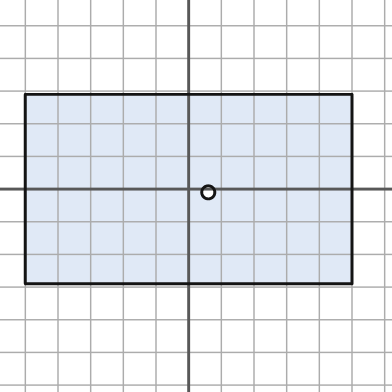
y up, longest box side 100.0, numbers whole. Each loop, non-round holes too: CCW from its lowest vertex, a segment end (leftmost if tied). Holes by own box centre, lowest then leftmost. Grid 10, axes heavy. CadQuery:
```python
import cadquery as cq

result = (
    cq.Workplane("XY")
    .moveTo(-50.0, -29.0)
    .lineTo(50.0, -29.0)
    .lineTo(50.0, 29.0)
    .lineTo(-50.0, 29.0)
    .close()
    .moveTo(6.0, -1.0)
    .circle(2.0)
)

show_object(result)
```